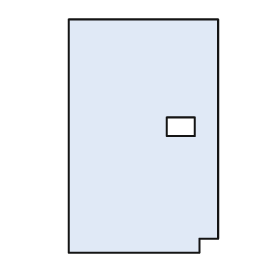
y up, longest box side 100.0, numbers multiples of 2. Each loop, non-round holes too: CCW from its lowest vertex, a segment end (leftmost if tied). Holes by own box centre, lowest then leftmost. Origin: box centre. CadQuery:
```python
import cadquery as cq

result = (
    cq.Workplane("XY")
    .moveTo(-32.0, -50.0)
    .lineTo(24.0, -50.0)
    .lineTo(24.0, -44.0)
    .lineTo(32.0, -44.0)
    .lineTo(32.0, 50.0)
    .lineTo(-32.0, 50.0)
    .close()
    .moveTo(10.0, 0.0)
    .lineTo(22.0, 0.0)
    .lineTo(22.0, 8.0)
    .lineTo(10.0, 8.0)
    .close()
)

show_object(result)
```